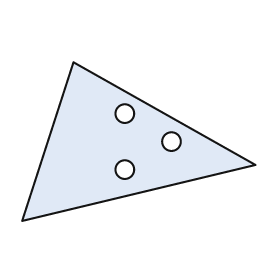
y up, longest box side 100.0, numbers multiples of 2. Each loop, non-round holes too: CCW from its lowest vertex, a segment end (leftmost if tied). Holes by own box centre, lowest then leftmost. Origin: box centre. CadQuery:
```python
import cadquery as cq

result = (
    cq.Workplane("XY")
    .moveTo(-50.0, -34.0)
    .lineTo(50.0, -10.0)
    .lineTo(-28.0, 34.0)
    .close()
    .moveTo(-6.0, -12.0)
    .circle(4.0)
    .moveTo(14.0, 0.0)
    .circle(4.0)
    .moveTo(-6.0, 12.0)
    .circle(4.0)
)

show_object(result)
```